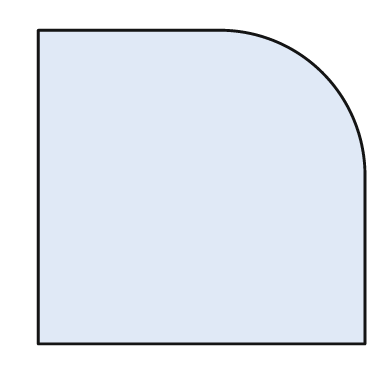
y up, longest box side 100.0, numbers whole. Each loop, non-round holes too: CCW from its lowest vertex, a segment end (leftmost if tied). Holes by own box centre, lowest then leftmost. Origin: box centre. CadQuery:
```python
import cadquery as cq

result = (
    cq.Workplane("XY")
    .moveTo(-50.0, -48.0)
    .lineTo(50.0, -48.0)
    .lineTo(50.0, 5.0)
    .threePointArc((37.0, 35.0), (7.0, 48.0))
    .lineTo(-50.0, 48.0)
    .close()
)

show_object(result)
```